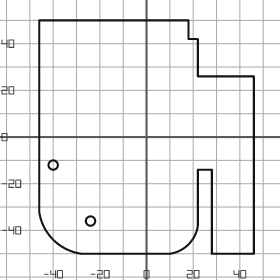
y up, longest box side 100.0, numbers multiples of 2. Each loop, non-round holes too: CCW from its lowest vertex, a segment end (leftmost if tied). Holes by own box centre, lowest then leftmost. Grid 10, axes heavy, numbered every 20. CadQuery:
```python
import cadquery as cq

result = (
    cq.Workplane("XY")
    .moveTo(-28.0, -50.0)
    .lineTo(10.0, -50.0)
    .threePointArc((18.0, -46.0), (22.0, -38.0))
    .lineTo(22.0, -14.0)
    .lineTo(28.0, -14.0)
    .lineTo(28.0, -50.0)
    .lineTo(46.0, -50.0)
    .lineTo(46.0, 26.0)
    .lineTo(22.0, 26.0)
    .lineTo(22.0, 42.0)
    .lineTo(18.0, 42.0)
    .lineTo(18.0, 50.0)
    .lineTo(-46.0, 50.0)
    .lineTo(-46.0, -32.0)
    .threePointArc((-40.0, -44.0), (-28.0, -50.0))
    .close()
    .moveTo(-24.0, -36.0)
    .circle(2.0)
    .moveTo(-40.0, -12.0)
    .circle(2.0)
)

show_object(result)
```